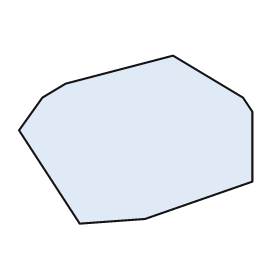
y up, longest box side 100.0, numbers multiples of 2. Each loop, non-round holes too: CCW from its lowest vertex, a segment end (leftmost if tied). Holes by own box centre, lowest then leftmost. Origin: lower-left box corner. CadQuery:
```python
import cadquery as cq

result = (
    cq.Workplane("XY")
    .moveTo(26.0, 0.0)
    .lineTo(54.0, 2.0)
    .lineTo(100.0, 18.0)
    .lineTo(100.0, 48.0)
    .lineTo(96.0, 54.0)
    .lineTo(66.0, 72.0)
    .lineTo(20.0, 60.0)
    .lineTo(10.0, 54.0)
    .lineTo(0.0, 40.0)
    .close()
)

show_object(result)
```